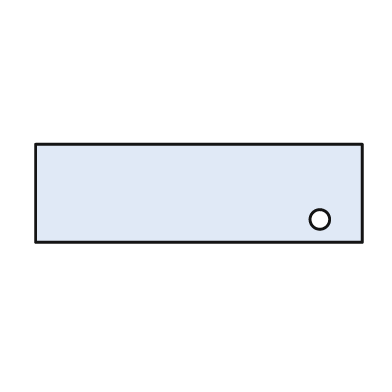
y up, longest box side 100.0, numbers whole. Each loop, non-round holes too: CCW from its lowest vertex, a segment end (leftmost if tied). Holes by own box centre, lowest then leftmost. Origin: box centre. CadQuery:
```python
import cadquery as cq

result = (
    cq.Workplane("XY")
    .moveTo(-50.0, -15.0)
    .lineTo(50.0, -15.0)
    .lineTo(50.0, 15.0)
    .lineTo(-50.0, 15.0)
    .close()
    .moveTo(37.0, -8.0)
    .circle(3.0)
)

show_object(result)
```